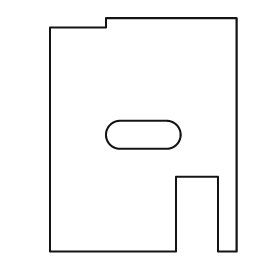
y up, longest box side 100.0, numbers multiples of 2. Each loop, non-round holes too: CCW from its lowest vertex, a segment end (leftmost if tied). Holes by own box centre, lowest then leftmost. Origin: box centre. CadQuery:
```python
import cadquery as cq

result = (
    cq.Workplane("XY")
    .moveTo(-40.0, -50.0)
    .lineTo(14.0, -50.0)
    .lineTo(14.0, -18.0)
    .lineTo(32.0, -18.0)
    .lineTo(32.0, -50.0)
    .lineTo(40.0, -50.0)
    .lineTo(40.0, 50.0)
    .lineTo(-16.0, 50.0)
    .lineTo(-16.0, 46.0)
    .lineTo(-40.0, 46.0)
    .close()
    .moveTo(-10.0, -6.0)
    .lineTo(10.0, -6.0)
    .threePointArc((16.0, 0.0), (10.0, 6.0))
    .lineTo(-10.0, 6.0)
    .threePointArc((-16.0, 0.0), (-10.0, -6.0))
    .close()
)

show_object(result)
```